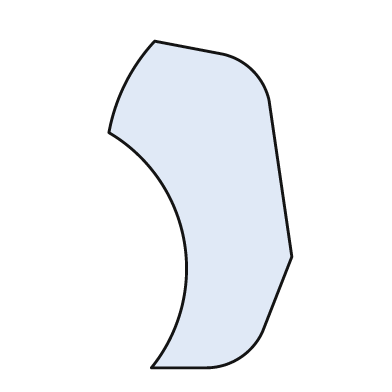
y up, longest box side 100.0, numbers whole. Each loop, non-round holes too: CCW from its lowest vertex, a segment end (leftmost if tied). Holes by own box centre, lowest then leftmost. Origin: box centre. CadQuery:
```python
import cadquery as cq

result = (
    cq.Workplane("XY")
    .moveTo(-15.0, -50.0)
    .lineTo(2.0, -50.0)
    .threePointArc((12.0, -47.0), (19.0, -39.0))
    .lineTo(28.0, -16.0)
    .lineTo(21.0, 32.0)
    .threePointArc((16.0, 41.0), (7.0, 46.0))
    .lineTo(-14.0, 50.0)
    .threePointArc((-23.0, 37.0), (-28.0, 22.0))
    .threePointArc((-5.0, -11.0), (-15.0, -50.0))
    .close()
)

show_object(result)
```